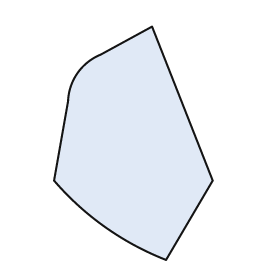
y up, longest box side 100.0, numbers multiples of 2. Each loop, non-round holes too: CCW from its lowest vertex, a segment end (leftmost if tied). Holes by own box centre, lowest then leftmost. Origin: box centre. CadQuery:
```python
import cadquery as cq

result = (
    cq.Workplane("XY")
    .moveTo(14.0, -50.0)
    .lineTo(34.0, -16.0)
    .lineTo(8.0, 50.0)
    .lineTo(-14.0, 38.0)
    .threePointArc((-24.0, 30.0), (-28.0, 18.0))
    .lineTo(-34.0, -16.0)
    .threePointArc((-12.0, -36.0), (14.0, -50.0))
    .close()
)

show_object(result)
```